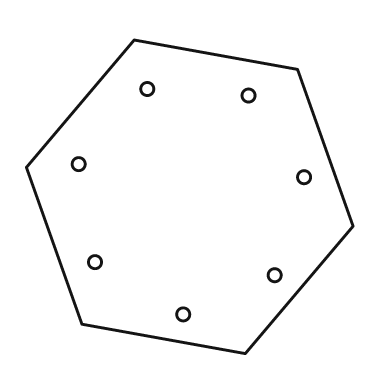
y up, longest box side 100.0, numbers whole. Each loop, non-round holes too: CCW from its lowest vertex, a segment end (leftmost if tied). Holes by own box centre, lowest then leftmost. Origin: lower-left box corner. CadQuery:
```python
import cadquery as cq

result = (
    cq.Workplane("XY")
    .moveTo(67.0, 0.0)
    .lineTo(100.0, 39.0)
    .lineTo(83.0, 87.0)
    .lineTo(33.0, 96.0)
    .lineTo(0.0, 57.0)
    .lineTo(17.0, 9.0)
    .close()
    .moveTo(48.0, 12.0)
    .circle(2.0)
    .moveTo(76.0, 24.0)
    .circle(2.0)
    .moveTo(21.0, 28.0)
    .circle(2.0)
    .moveTo(85.0, 54.0)
    .circle(2.0)
    .moveTo(16.0, 58.0)
    .circle(2.0)
    .moveTo(68.0, 79.0)
    .circle(2.0)
    .moveTo(37.0, 81.0)
    .circle(2.0)
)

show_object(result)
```